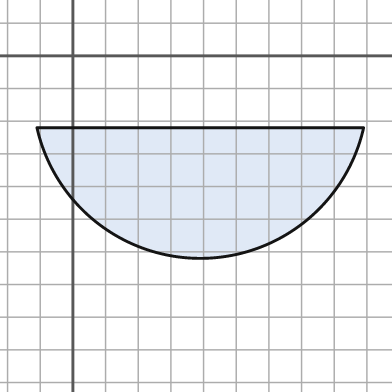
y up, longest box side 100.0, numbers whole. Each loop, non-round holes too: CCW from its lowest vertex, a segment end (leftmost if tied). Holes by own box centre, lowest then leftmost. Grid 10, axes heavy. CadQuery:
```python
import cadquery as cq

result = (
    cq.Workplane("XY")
    .moveTo(-11.0, -22.0)
    .threePointArc((39.0, -62.0), (89.0, -22.0))
    .close()
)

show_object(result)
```